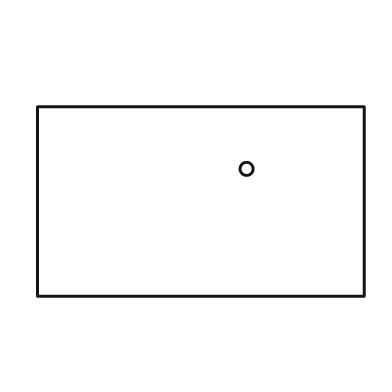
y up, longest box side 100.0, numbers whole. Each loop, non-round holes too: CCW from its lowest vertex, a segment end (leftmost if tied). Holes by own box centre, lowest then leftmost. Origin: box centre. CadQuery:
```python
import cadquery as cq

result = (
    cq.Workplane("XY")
    .moveTo(-50.0, -29.0)
    .lineTo(50.0, -29.0)
    .lineTo(50.0, 29.0)
    .lineTo(-50.0, 29.0)
    .close()
    .moveTo(14.0, 10.0)
    .circle(2.0)
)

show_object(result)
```